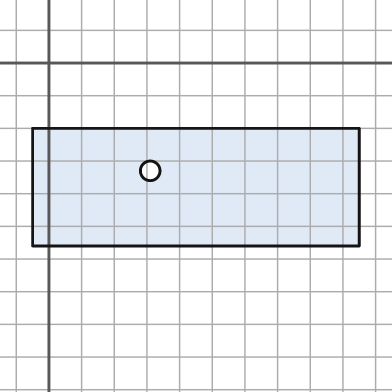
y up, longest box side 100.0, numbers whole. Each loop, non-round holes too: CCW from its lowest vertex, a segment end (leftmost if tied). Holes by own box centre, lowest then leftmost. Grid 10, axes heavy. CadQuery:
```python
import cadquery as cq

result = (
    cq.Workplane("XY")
    .moveTo(-5.0, -56.0)
    .lineTo(95.0, -56.0)
    .lineTo(95.0, -20.0)
    .lineTo(-5.0, -20.0)
    .close()
    .moveTo(31.0, -33.0)
    .circle(3.0)
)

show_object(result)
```